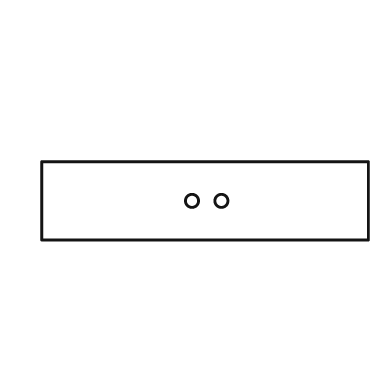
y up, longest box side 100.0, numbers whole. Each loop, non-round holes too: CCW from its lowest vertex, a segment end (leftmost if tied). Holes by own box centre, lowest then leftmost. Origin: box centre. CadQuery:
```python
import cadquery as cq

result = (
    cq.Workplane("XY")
    .moveTo(-50.0, -12.0)
    .lineTo(50.0, -12.0)
    .lineTo(50.0, 12.0)
    .lineTo(-50.0, 12.0)
    .close()
    .moveTo(-4.0, 0.0)
    .circle(2.0)
    .moveTo(5.0, 0.0)
    .circle(2.0)
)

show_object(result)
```